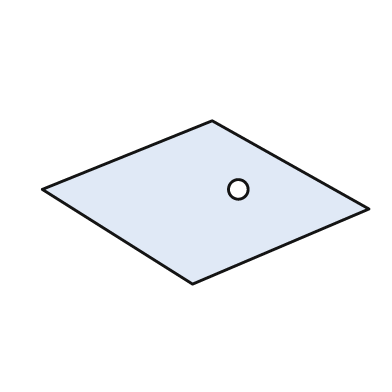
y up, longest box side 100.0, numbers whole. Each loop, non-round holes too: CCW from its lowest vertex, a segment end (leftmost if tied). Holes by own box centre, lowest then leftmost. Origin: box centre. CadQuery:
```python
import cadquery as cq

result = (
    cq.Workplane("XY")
    .moveTo(-4.0, -25.0)
    .lineTo(50.0, -2.0)
    .lineTo(2.0, 25.0)
    .lineTo(-50.0, 4.0)
    .close()
    .moveTo(10.0, 4.0)
    .circle(3.0)
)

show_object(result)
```